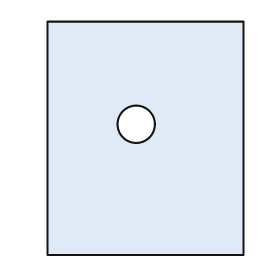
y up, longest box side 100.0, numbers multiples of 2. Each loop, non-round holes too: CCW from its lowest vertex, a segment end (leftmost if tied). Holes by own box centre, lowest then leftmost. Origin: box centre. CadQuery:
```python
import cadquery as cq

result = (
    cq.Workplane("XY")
    .moveTo(-42.0, -50.0)
    .lineTo(42.0, -50.0)
    .lineTo(42.0, 50.0)
    .lineTo(-42.0, 50.0)
    .close()
    .moveTo(-4.0, 6.0)
    .circle(8.0)
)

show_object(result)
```